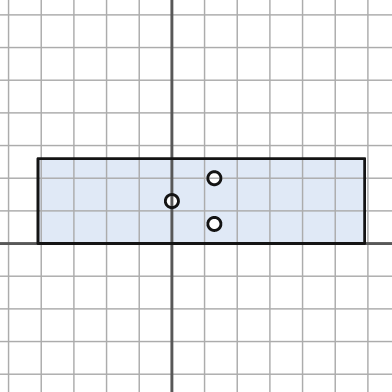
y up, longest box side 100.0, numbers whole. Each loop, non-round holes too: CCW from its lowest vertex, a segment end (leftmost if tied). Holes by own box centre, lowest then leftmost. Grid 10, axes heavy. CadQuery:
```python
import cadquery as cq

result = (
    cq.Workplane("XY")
    .moveTo(-41.0, 0.0)
    .lineTo(59.0, 0.0)
    .lineTo(59.0, 26.0)
    .lineTo(-41.0, 26.0)
    .close()
    .moveTo(13.0, 6.0)
    .circle(2.0)
    .moveTo(0.0, 13.0)
    .circle(2.0)
    .moveTo(13.0, 20.0)
    .circle(2.0)
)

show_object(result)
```